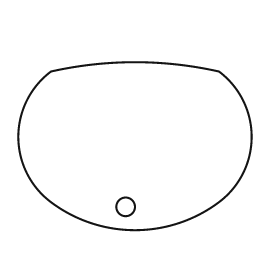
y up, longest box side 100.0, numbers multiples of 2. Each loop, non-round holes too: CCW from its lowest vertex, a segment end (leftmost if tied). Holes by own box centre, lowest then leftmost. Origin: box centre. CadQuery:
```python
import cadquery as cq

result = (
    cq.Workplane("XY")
    .moveTo(-36.0, -24.0)
    .threePointArc((0.0, -36.0), (36.0, -24.0))
    .threePointArc((50.0, 4.0), (36.0, 32.0))
    .threePointArc((0.0, 36.0), (-36.0, 32.0))
    .threePointArc((-50.0, 4.0), (-36.0, -24.0))
    .close()
    .moveTo(-4.0, -26.0)
    .circle(4.0)
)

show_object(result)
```